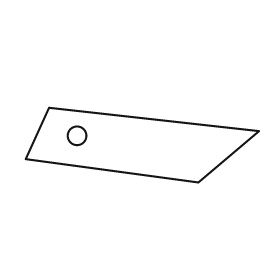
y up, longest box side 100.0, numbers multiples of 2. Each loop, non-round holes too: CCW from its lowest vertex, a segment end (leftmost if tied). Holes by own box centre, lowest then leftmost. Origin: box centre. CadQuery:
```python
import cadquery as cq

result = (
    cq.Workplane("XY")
    .moveTo(24.0, -16.0)
    .lineTo(50.0, 6.0)
    .lineTo(-40.0, 16.0)
    .lineTo(-50.0, -6.0)
    .close()
    .moveTo(-28.0, 4.0)
    .circle(4.0)
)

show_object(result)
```